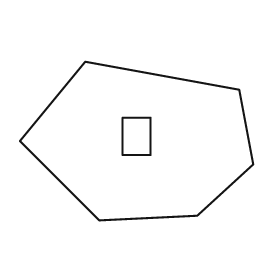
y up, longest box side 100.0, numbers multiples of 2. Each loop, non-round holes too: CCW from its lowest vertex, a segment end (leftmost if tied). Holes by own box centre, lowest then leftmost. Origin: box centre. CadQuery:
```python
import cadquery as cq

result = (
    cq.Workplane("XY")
    .moveTo(-16.0, -34.0)
    .lineTo(26.0, -32.0)
    .lineTo(50.0, -10.0)
    .lineTo(44.0, 22.0)
    .lineTo(-22.0, 34.0)
    .lineTo(-50.0, 0.0)
    .close()
    .moveTo(-6.0, -6.0)
    .lineTo(6.0, -6.0)
    .lineTo(6.0, 10.0)
    .lineTo(-6.0, 10.0)
    .close()
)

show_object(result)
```